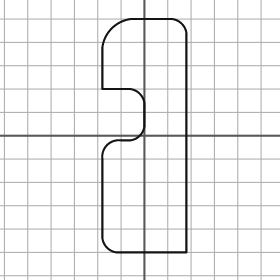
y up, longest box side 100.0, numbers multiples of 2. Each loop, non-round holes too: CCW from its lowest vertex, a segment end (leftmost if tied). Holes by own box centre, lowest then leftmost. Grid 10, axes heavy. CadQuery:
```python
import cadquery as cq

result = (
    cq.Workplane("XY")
    .moveTo(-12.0, -50.0)
    .lineTo(18.0, -50.0)
    .lineTo(18.0, 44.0)
    .threePointArc((16.0, 48.0), (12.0, 50.0))
    .lineTo(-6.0, 50.0)
    .threePointArc((-14.0, 46.0), (-18.0, 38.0))
    .lineTo(-18.0, 20.0)
    .lineTo(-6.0, 20.0)
    .threePointArc((-2.0, 18.0), (0.0, 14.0))
    .lineTo(0.0, 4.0)
    .threePointArc((-2.0, 0.0), (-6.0, -2.0))
    .lineTo(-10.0, -2.0)
    .threePointArc((-16.0, -4.0), (-18.0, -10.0))
    .lineTo(-18.0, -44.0)
    .threePointArc((-16.0, -48.0), (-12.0, -50.0))
    .close()
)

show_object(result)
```